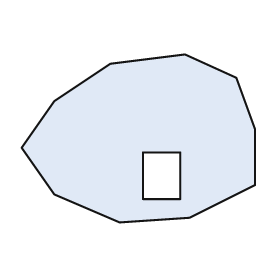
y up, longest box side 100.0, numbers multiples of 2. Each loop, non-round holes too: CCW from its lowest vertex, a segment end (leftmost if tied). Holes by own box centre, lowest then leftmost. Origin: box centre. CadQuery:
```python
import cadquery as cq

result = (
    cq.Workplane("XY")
    .moveTo(-8.0, -36.0)
    .lineTo(22.0, -34.0)
    .lineTo(50.0, -20.0)
    .lineTo(50.0, 4.0)
    .lineTo(42.0, 26.0)
    .lineTo(20.0, 36.0)
    .lineTo(-12.0, 32.0)
    .lineTo(-36.0, 16.0)
    .lineTo(-50.0, -4.0)
    .lineTo(-36.0, -24.0)
    .close()
    .moveTo(2.0, -26.0)
    .lineTo(18.0, -26.0)
    .lineTo(18.0, -6.0)
    .lineTo(2.0, -6.0)
    .close()
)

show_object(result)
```